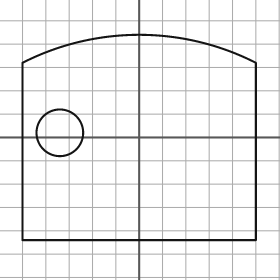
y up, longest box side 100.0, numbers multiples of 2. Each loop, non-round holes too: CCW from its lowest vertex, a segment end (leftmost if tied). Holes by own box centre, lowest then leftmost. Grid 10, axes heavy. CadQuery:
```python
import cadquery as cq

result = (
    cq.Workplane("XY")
    .moveTo(-50.0, -44.0)
    .lineTo(50.0, -44.0)
    .lineTo(50.0, 32.0)
    .threePointArc((0.0, 44.0), (-50.0, 32.0))
    .close()
    .moveTo(-34.0, 2.0)
    .circle(10.0)
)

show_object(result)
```